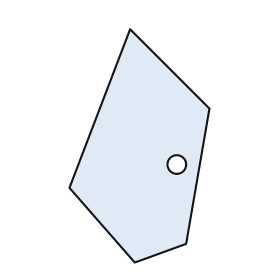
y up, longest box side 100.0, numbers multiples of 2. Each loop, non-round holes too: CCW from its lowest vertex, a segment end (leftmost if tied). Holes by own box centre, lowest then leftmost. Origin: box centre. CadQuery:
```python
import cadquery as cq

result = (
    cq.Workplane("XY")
    .moveTo(-2.0, -50.0)
    .lineTo(20.0, -42.0)
    .lineTo(30.0, 16.0)
    .lineTo(-4.0, 50.0)
    .lineTo(-30.0, -18.0)
    .close()
    .moveTo(16.0, -8.0)
    .circle(4.0)
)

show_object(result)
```